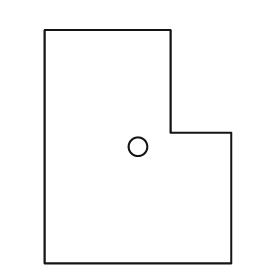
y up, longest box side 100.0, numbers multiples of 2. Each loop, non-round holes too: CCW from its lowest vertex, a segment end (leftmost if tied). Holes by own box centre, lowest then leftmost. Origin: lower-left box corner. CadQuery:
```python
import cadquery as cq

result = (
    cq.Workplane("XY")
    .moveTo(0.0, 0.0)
    .lineTo(80.0, 0.0)
    .lineTo(80.0, 56.0)
    .lineTo(54.0, 56.0)
    .lineTo(54.0, 100.0)
    .lineTo(0.0, 100.0)
    .close()
    .moveTo(40.0, 50.0)
    .circle(4.0)
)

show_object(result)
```